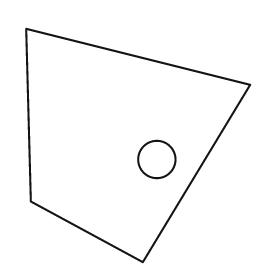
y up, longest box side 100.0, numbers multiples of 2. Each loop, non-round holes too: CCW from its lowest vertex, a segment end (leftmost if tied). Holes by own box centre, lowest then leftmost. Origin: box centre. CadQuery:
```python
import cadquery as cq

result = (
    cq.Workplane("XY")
    .moveTo(2.0, -50.0)
    .lineTo(48.0, 26.0)
    .lineTo(-48.0, 50.0)
    .lineTo(-46.0, -24.0)
    .close()
    .moveTo(8.0, -6.0)
    .circle(8.0)
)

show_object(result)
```